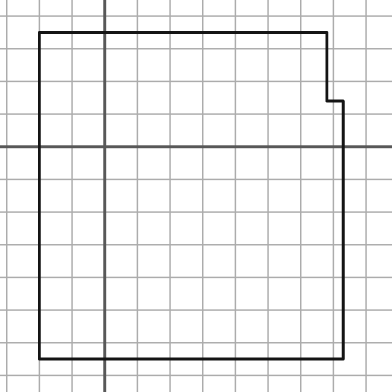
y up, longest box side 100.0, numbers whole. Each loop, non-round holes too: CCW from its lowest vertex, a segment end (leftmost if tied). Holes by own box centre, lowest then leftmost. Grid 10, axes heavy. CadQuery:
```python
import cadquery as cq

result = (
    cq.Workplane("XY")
    .moveTo(-20.0, -65.0)
    .lineTo(73.0, -65.0)
    .lineTo(73.0, 14.0)
    .lineTo(68.0, 14.0)
    .lineTo(68.0, 35.0)
    .lineTo(-20.0, 35.0)
    .close()
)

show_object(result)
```